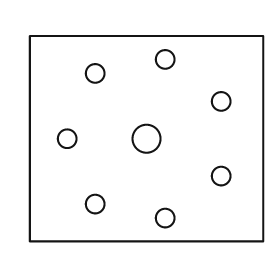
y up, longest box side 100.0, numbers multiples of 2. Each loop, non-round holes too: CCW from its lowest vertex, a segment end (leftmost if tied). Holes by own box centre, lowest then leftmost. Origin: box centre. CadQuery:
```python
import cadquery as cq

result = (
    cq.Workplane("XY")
    .moveTo(-50.0, -44.0)
    .lineTo(50.0, -44.0)
    .lineTo(50.0, 44.0)
    .lineTo(-50.0, 44.0)
    .close()
    .moveTo(8.0, -34.0)
    .circle(4.0)
    .moveTo(-22.0, -28.0)
    .circle(4.0)
    .moveTo(32.0, -16.0)
    .circle(4.0)
    .moveTo(-34.0, 0.0)
    .circle(4.0)
    .moveTo(0.0, 0.0)
    .circle(6.0)
    .moveTo(32.0, 16.0)
    .circle(4.0)
    .moveTo(-22.0, 28.0)
    .circle(4.0)
    .moveTo(8.0, 34.0)
    .circle(4.0)
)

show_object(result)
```